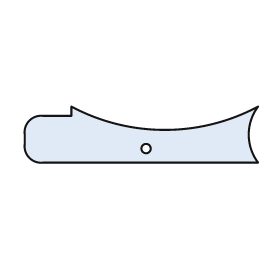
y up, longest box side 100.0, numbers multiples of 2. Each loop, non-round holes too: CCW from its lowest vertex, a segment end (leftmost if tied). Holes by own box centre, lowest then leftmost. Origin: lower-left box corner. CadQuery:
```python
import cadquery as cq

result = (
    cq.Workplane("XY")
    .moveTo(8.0, 0.0)
    .lineTo(100.0, 0.0)
    .threePointArc((96.0, 12.0), (100.0, 24.0))
    .threePointArc((60.0, 14.0), (20.0, 24.0))
    .lineTo(20.0, 20.0)
    .lineTo(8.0, 20.0)
    .threePointArc((2.0, 18.0), (0.0, 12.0))
    .lineTo(0.0, 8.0)
    .threePointArc((2.0, 2.0), (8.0, 0.0))
    .close()
    .moveTo(52.0, 6.0)
    .circle(2.0)
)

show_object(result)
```